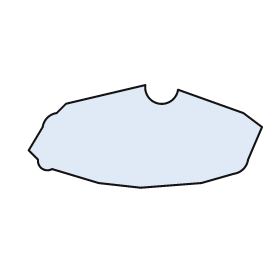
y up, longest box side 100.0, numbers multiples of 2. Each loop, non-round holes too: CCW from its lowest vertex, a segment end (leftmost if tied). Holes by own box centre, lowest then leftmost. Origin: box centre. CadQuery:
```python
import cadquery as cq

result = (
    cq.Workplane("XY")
    .moveTo(-2.0, -22.0)
    .lineTo(24.0, -20.0)
    .lineTo(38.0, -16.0)
    .threePointArc((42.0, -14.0), (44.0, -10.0))
    .lineTo(50.0, 4.0)
    .lineTo(42.0, 10.0)
    .lineTo(14.0, 20.0)
    .threePointArc((6.0, 14.0), (0.0, 22.0))
    .lineTo(-34.0, 14.0)
    .lineTo(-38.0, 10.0)
    .threePointArc((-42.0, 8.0), (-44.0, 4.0))
    .lineTo(-50.0, -6.0)
    .lineTo(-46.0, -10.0)
    .threePointArc((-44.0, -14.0), (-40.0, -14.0))
    .lineTo(-20.0, -20.0)
    .close()
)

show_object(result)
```